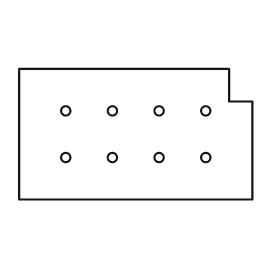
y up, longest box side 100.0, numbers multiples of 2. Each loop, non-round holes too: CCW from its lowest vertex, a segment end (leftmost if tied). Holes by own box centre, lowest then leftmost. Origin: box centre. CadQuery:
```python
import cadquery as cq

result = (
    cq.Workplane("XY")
    .moveTo(-50.0, -28.0)
    .lineTo(50.0, -28.0)
    .lineTo(50.0, 14.0)
    .lineTo(40.0, 14.0)
    .lineTo(40.0, 28.0)
    .lineTo(-50.0, 28.0)
    .close()
    .moveTo(-30.0, -10.0)
    .circle(2.0)
    .moveTo(-10.0, -10.0)
    .circle(2.0)
    .moveTo(10.0, -10.0)
    .circle(2.0)
    .moveTo(30.0, -10.0)
    .circle(2.0)
    .moveTo(-30.0, 10.0)
    .circle(2.0)
    .moveTo(-10.0, 10.0)
    .circle(2.0)
    .moveTo(10.0, 10.0)
    .circle(2.0)
    .moveTo(30.0, 10.0)
    .circle(2.0)
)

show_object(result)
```